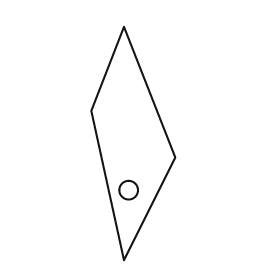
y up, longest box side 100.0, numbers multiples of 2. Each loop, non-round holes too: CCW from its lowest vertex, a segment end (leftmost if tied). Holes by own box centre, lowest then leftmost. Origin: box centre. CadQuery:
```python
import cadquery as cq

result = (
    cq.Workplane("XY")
    .moveTo(-4.0, -50.0)
    .lineTo(18.0, -6.0)
    .lineTo(-4.0, 50.0)
    .lineTo(-18.0, 14.0)
    .close()
    .moveTo(-2.0, -20.0)
    .circle(4.0)
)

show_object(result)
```